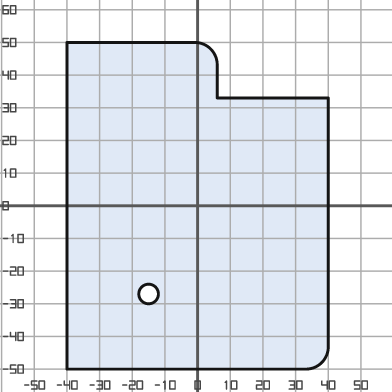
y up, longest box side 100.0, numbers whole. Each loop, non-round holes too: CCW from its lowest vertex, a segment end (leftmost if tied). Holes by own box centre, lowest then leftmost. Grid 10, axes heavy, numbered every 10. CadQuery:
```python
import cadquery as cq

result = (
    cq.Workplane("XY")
    .moveTo(-40.0, -50.0)
    .lineTo(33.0, -50.0)
    .threePointArc((38.0, -48.0), (40.0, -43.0))
    .lineTo(40.0, 33.0)
    .lineTo(6.0, 33.0)
    .lineTo(6.0, 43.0)
    .threePointArc((4.0, 48.0), (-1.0, 50.0))
    .lineTo(-40.0, 50.0)
    .close()
    .moveTo(-15.0, -27.0)
    .circle(3.0)
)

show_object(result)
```